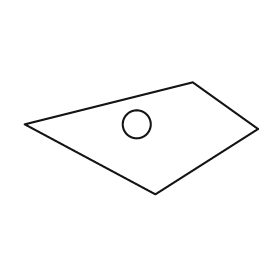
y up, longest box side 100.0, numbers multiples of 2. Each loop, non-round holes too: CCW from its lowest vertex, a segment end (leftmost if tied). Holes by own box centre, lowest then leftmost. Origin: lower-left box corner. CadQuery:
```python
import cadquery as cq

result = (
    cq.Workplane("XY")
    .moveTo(56.0, 0.0)
    .lineTo(100.0, 28.0)
    .lineTo(72.0, 48.0)
    .lineTo(0.0, 30.0)
    .close()
    .moveTo(48.0, 30.0)
    .circle(6.0)
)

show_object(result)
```